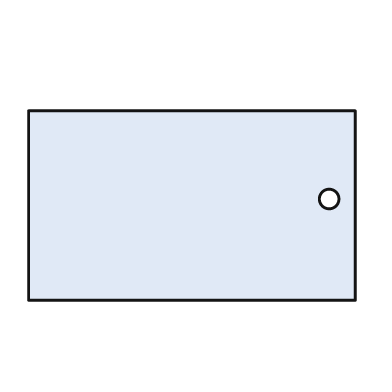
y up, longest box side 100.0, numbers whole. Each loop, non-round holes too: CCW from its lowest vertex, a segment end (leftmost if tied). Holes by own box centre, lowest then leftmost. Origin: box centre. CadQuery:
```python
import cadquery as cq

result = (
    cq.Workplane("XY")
    .moveTo(-50.0, -29.0)
    .lineTo(50.0, -29.0)
    .lineTo(50.0, 29.0)
    .lineTo(-50.0, 29.0)
    .close()
    .moveTo(42.0, 2.0)
    .circle(3.0)
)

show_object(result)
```